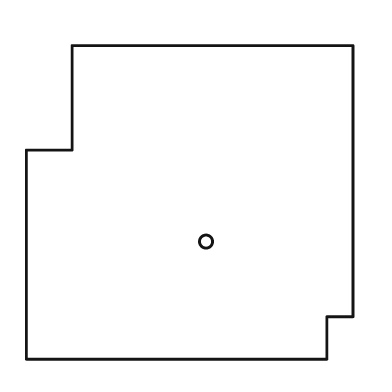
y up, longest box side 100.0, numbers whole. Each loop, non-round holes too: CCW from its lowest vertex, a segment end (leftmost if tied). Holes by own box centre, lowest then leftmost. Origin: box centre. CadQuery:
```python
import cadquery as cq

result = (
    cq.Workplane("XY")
    .moveTo(-50.0, -48.0)
    .lineTo(42.0, -48.0)
    .lineTo(42.0, -35.0)
    .lineTo(50.0, -35.0)
    .lineTo(50.0, 48.0)
    .lineTo(-36.0, 48.0)
    .lineTo(-36.0, 16.0)
    .lineTo(-50.0, 16.0)
    .close()
    .moveTo(5.0, -12.0)
    .circle(2.0)
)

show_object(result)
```